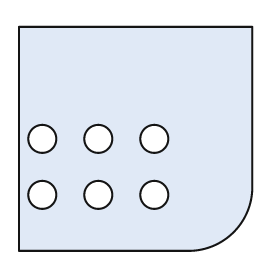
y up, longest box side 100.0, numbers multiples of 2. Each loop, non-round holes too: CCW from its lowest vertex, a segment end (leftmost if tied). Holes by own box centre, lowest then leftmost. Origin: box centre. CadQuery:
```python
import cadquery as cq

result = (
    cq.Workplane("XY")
    .moveTo(-50.0, -48.0)
    .lineTo(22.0, -48.0)
    .threePointArc((42.0, -40.0), (50.0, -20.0))
    .lineTo(50.0, 48.0)
    .lineTo(-50.0, 48.0)
    .close()
    .moveTo(-40.0, -24.0)
    .circle(6.0)
    .moveTo(-16.0, -24.0)
    .circle(6.0)
    .moveTo(8.0, -24.0)
    .circle(6.0)
    .moveTo(-40.0, 0.0)
    .circle(6.0)
    .moveTo(-16.0, 0.0)
    .circle(6.0)
    .moveTo(8.0, 0.0)
    .circle(6.0)
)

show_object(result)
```